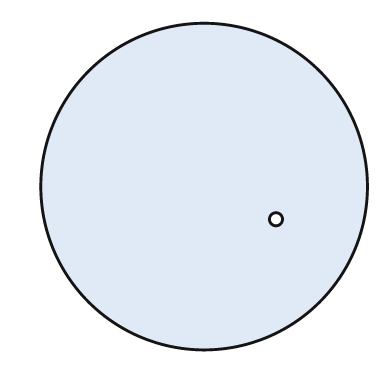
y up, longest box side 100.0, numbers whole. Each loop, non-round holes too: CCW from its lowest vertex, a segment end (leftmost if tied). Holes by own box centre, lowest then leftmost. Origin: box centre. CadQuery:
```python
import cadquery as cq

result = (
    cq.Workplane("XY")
    .moveTo(0.0, 0.0)
    .circle(50.0)
    .moveTo(22.0, -10.0)
    .circle(2.0)
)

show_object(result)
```